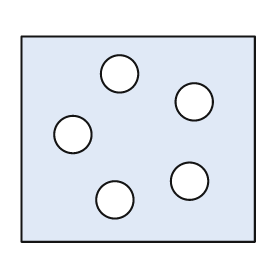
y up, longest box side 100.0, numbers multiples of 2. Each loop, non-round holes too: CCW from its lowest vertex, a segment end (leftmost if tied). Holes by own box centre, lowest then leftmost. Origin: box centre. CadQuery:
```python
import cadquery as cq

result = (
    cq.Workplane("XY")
    .moveTo(-50.0, -44.0)
    .lineTo(50.0, -44.0)
    .lineTo(50.0, 44.0)
    .lineTo(-50.0, 44.0)
    .close()
    .moveTo(-10.0, -26.0)
    .circle(8.0)
    .moveTo(22.0, -18.0)
    .circle(8.0)
    .moveTo(-28.0, 2.0)
    .circle(8.0)
    .moveTo(24.0, 16.0)
    .circle(8.0)
    .moveTo(-8.0, 28.0)
    .circle(8.0)
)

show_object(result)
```